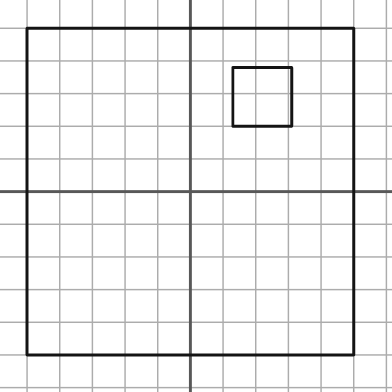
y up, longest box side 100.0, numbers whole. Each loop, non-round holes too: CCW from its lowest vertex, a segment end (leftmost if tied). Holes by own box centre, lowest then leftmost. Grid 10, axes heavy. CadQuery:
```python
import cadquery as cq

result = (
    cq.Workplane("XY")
    .moveTo(-50.0, -50.0)
    .lineTo(50.0, -50.0)
    .lineTo(50.0, 50.0)
    .lineTo(-50.0, 50.0)
    .close()
    .moveTo(13.0, 20.0)
    .lineTo(31.0, 20.0)
    .lineTo(31.0, 38.0)
    .lineTo(13.0, 38.0)
    .close()
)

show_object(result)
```